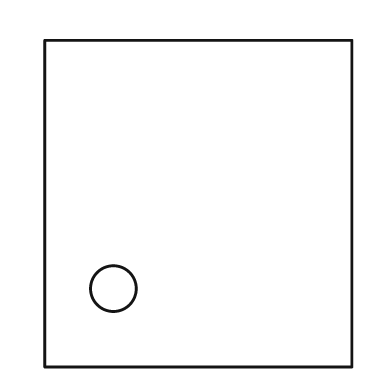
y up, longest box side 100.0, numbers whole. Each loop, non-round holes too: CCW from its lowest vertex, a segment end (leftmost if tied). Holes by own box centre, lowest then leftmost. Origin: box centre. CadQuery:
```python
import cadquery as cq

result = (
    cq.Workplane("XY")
    .moveTo(-47.0, -50.0)
    .lineTo(47.0, -50.0)
    .lineTo(47.0, 50.0)
    .lineTo(-47.0, 50.0)
    .close()
    .moveTo(-26.0, -26.0)
    .circle(7.0)
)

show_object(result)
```